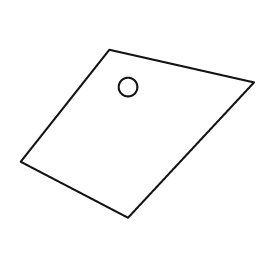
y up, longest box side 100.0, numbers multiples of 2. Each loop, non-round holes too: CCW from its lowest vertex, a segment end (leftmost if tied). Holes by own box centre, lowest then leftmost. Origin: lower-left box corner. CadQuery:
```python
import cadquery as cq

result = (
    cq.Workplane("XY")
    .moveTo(46.0, 0.0)
    .lineTo(100.0, 58.0)
    .lineTo(38.0, 72.0)
    .lineTo(0.0, 24.0)
    .close()
    .moveTo(46.0, 56.0)
    .circle(4.0)
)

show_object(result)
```